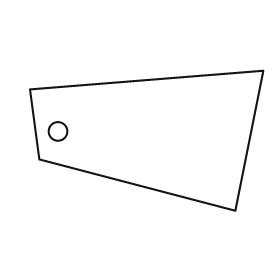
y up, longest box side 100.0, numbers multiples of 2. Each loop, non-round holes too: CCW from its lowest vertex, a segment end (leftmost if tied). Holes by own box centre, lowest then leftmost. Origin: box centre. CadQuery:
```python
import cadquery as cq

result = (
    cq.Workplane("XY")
    .moveTo(38.0, -30.0)
    .lineTo(50.0, 30.0)
    .lineTo(-50.0, 22.0)
    .lineTo(-46.0, -8.0)
    .close()
    .moveTo(-38.0, 4.0)
    .circle(4.0)
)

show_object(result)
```